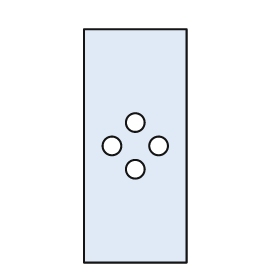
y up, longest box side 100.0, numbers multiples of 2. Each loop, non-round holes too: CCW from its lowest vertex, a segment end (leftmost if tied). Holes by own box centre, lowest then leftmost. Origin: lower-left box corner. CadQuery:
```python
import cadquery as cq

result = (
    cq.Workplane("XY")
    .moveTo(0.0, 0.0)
    .lineTo(44.0, 0.0)
    .lineTo(44.0, 100.0)
    .lineTo(0.0, 100.0)
    .close()
    .moveTo(22.0, 40.0)
    .circle(4.0)
    .moveTo(12.0, 50.0)
    .circle(4.0)
    .moveTo(32.0, 50.0)
    .circle(4.0)
    .moveTo(22.0, 60.0)
    .circle(4.0)
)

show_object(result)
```